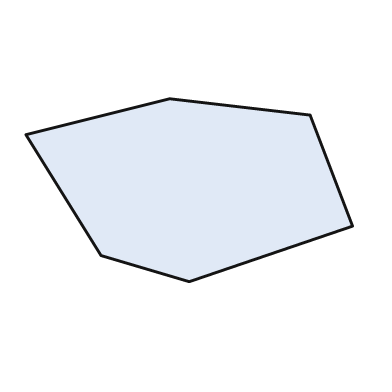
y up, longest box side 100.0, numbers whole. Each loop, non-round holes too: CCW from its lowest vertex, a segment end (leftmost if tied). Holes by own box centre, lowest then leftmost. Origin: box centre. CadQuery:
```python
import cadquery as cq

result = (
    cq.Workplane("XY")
    .moveTo(0.0, -28.0)
    .lineTo(50.0, -11.0)
    .lineTo(37.0, 23.0)
    .lineTo(-6.0, 28.0)
    .lineTo(-50.0, 17.0)
    .lineTo(-27.0, -20.0)
    .close()
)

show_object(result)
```